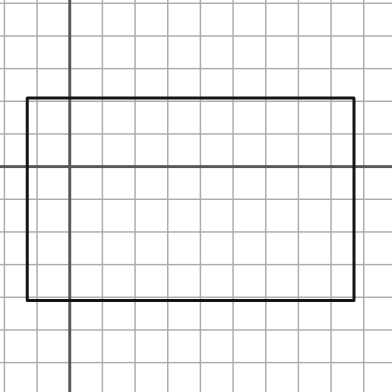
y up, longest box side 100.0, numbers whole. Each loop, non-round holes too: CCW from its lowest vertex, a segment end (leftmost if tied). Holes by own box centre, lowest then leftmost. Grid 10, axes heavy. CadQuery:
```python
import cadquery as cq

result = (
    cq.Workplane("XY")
    .moveTo(-13.0, -41.0)
    .lineTo(87.0, -41.0)
    .lineTo(87.0, 21.0)
    .lineTo(-13.0, 21.0)
    .close()
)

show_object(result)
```